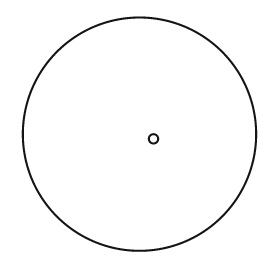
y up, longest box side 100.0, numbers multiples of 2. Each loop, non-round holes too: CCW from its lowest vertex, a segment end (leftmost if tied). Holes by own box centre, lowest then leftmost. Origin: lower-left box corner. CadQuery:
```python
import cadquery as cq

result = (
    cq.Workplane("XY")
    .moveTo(50.0, 50.0)
    .circle(50.0)
    .moveTo(56.0, 48.0)
    .circle(2.0)
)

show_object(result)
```